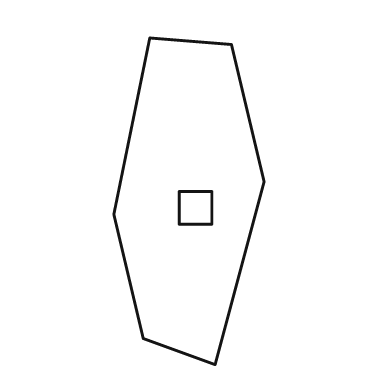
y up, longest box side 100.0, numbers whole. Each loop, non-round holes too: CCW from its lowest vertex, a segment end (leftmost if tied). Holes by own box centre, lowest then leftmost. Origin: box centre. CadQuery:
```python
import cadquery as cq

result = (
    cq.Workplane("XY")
    .moveTo(8.0, -50.0)
    .lineTo(23.0, 6.0)
    .lineTo(13.0, 48.0)
    .lineTo(-12.0, 50.0)
    .lineTo(-23.0, -4.0)
    .lineTo(-14.0, -42.0)
    .close()
    .moveTo(-3.0, -7.0)
    .lineTo(7.0, -7.0)
    .lineTo(7.0, 3.0)
    .lineTo(-3.0, 3.0)
    .close()
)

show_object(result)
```